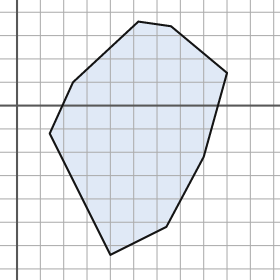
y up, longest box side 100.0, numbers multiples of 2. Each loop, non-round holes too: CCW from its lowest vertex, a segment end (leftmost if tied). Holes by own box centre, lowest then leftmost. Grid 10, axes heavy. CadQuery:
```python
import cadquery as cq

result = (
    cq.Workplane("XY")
    .moveTo(40.0, -64.0)
    .lineTo(64.0, -52.0)
    .lineTo(80.0, -22.0)
    .lineTo(90.0, 14.0)
    .lineTo(66.0, 34.0)
    .lineTo(52.0, 36.0)
    .lineTo(24.0, 10.0)
    .lineTo(14.0, -12.0)
    .close()
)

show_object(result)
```